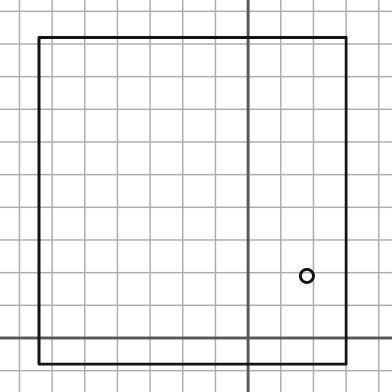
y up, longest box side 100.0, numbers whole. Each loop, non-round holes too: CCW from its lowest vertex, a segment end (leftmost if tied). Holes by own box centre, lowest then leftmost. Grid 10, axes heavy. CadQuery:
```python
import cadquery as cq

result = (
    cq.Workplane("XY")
    .moveTo(-64.0, -8.0)
    .lineTo(30.0, -8.0)
    .lineTo(30.0, 92.0)
    .lineTo(-64.0, 92.0)
    .close()
    .moveTo(18.0, 19.0)
    .circle(2.0)
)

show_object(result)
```